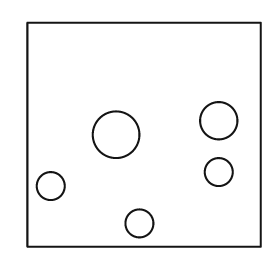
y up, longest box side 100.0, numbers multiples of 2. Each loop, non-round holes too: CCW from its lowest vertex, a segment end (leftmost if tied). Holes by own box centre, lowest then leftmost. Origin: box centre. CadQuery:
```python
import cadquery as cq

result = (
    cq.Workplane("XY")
    .moveTo(-50.0, -48.0)
    .lineTo(50.0, -48.0)
    .lineTo(50.0, 48.0)
    .lineTo(-50.0, 48.0)
    .close()
    .moveTo(-2.0, -38.0)
    .circle(6.0)
    .moveTo(-40.0, -22.0)
    .circle(6.0)
    .moveTo(32.0, -16.0)
    .circle(6.0)
    .moveTo(-12.0, 0.0)
    .circle(10.0)
    .moveTo(32.0, 6.0)
    .circle(8.0)
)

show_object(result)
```